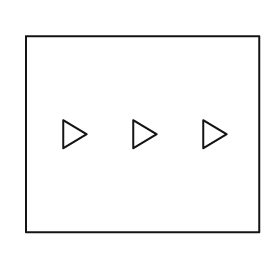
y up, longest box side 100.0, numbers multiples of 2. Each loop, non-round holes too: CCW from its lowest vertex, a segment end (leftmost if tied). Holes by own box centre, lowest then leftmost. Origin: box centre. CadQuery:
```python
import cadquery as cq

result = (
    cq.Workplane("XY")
    .moveTo(-50.0, -42.0)
    .lineTo(50.0, -42.0)
    .lineTo(50.0, 42.0)
    .lineTo(-50.0, 42.0)
    .close()
    .moveTo(-34.0, -6.0)
    .lineTo(-24.0, 0.0)
    .lineTo(-34.0, 6.0)
    .close()
    .moveTo(-4.0, -6.0)
    .lineTo(6.0, 0.0)
    .lineTo(-4.0, 6.0)
    .close()
    .moveTo(26.0, -6.0)
    .lineTo(36.0, 0.0)
    .lineTo(26.0, 6.0)
    .close()
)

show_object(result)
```